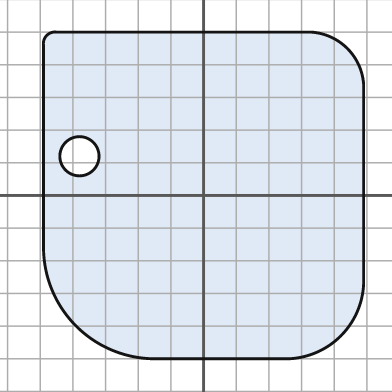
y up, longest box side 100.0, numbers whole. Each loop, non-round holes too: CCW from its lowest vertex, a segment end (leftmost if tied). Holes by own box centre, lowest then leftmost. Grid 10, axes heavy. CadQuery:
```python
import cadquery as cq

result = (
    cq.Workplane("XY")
    .moveTo(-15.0, -50.0)
    .lineTo(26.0, -50.0)
    .threePointArc((42.0, -43.0), (49.0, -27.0))
    .lineTo(49.0, 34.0)
    .threePointArc((44.0, 45.0), (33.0, 50.0))
    .lineTo(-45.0, 50.0)
    .threePointArc((-48.0, 49.0), (-49.0, 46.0))
    .lineTo(-49.0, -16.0)
    .threePointArc((-39.0, -40.0), (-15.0, -50.0))
    .close()
    .moveTo(-38.0, 12.0)
    .circle(6.0)
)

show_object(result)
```